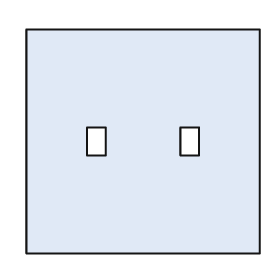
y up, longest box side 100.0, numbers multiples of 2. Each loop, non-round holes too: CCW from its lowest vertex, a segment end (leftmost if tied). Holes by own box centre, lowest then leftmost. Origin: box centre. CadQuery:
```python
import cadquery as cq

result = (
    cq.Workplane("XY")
    .moveTo(-50.0, -48.0)
    .lineTo(50.0, -48.0)
    .lineTo(50.0, 48.0)
    .lineTo(-50.0, 48.0)
    .close()
    .moveTo(-24.0, -6.0)
    .lineTo(-16.0, -6.0)
    .lineTo(-16.0, 6.0)
    .lineTo(-24.0, 6.0)
    .close()
    .moveTo(16.0, -6.0)
    .lineTo(24.0, -6.0)
    .lineTo(24.0, 6.0)
    .lineTo(16.0, 6.0)
    .close()
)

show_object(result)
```